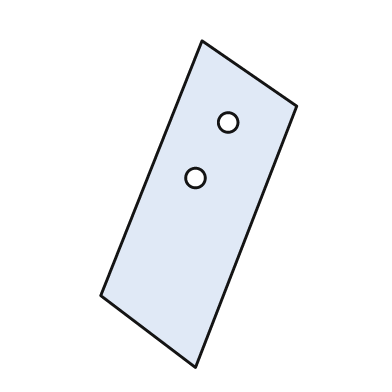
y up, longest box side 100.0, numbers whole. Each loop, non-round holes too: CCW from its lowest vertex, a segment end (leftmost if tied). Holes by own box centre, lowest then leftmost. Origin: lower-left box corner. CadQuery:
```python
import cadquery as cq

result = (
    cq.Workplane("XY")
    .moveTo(29.0, 0.0)
    .lineTo(60.0, 80.0)
    .lineTo(31.0, 100.0)
    .lineTo(0.0, 22.0)
    .close()
    .moveTo(29.0, 58.0)
    .circle(3.0)
    .moveTo(39.0, 75.0)
    .circle(3.0)
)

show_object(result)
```